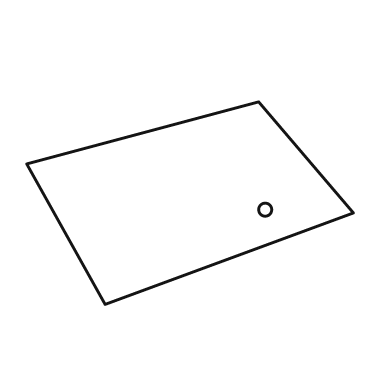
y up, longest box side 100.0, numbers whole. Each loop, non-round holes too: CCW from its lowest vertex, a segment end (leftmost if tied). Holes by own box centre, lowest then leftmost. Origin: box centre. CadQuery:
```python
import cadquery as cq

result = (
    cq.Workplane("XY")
    .moveTo(-26.0, -31.0)
    .lineTo(50.0, -3.0)
    .lineTo(21.0, 31.0)
    .lineTo(-50.0, 12.0)
    .close()
    .moveTo(23.0, -2.0)
    .circle(2.0)
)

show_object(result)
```